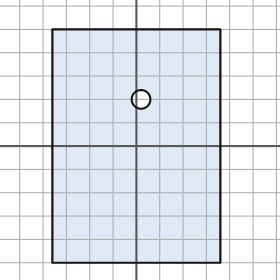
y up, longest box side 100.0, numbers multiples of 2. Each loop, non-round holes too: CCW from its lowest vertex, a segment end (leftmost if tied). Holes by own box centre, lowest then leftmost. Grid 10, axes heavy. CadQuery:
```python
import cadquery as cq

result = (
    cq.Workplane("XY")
    .moveTo(-36.0, -50.0)
    .lineTo(36.0, -50.0)
    .lineTo(36.0, 50.0)
    .lineTo(-36.0, 50.0)
    .close()
    .moveTo(2.0, 20.0)
    .circle(4.0)
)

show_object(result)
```